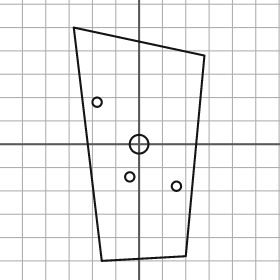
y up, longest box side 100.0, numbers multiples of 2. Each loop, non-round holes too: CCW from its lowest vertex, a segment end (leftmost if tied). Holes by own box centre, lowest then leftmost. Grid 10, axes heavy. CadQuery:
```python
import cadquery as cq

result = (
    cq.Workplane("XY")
    .moveTo(-16.0, -50.0)
    .lineTo(20.0, -48.0)
    .lineTo(28.0, 38.0)
    .lineTo(-28.0, 50.0)
    .close()
    .moveTo(16.0, -18.0)
    .circle(2.0)
    .moveTo(-4.0, -14.0)
    .circle(2.0)
    .moveTo(0.0, 0.0)
    .circle(4.0)
    .moveTo(-18.0, 18.0)
    .circle(2.0)
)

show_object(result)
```